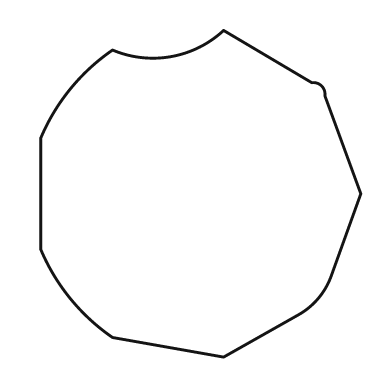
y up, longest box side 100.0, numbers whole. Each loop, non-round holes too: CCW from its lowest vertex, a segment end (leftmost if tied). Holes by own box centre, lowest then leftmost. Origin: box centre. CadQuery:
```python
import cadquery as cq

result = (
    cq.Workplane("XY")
    .moveTo(7.0, -50.0)
    .lineTo(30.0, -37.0)
    .threePointArc((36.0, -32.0), (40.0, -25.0))
    .lineTo(49.0, 0.0)
    .lineTo(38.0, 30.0)
    .threePointArc((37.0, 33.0), (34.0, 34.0))
    .lineTo(7.0, 50.0)
    .threePointArc((-9.0, 42.0), (-27.0, 44.0))
    .threePointArc((-40.0, 32.0), (-49.0, 17.0))
    .lineTo(-49.0, -17.0)
    .threePointArc((-40.0, -32.0), (-27.0, -44.0))
    .close()
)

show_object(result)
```